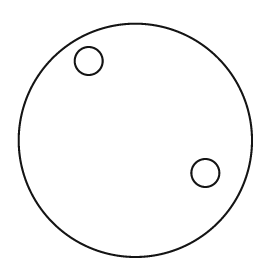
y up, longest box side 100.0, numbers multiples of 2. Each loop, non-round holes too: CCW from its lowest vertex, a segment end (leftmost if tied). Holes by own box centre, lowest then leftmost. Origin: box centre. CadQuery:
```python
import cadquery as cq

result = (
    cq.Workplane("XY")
    .moveTo(0.0, 0.0)
    .circle(50.0)
    .moveTo(30.0, -14.0)
    .circle(6.0)
    .moveTo(-20.0, 34.0)
    .circle(6.0)
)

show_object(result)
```